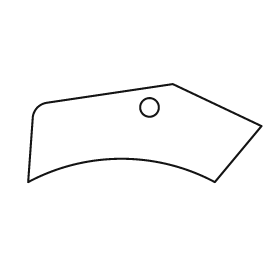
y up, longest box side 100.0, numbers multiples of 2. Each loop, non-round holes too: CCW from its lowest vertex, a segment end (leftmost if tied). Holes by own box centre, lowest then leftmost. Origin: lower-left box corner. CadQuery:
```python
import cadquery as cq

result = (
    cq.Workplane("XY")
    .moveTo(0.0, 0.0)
    .threePointArc((40.0, 10.0), (80.0, 0.0))
    .lineTo(100.0, 24.0)
    .lineTo(62.0, 42.0)
    .lineTo(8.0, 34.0)
    .threePointArc((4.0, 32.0), (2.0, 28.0))
    .close()
    .moveTo(52.0, 32.0)
    .circle(4.0)
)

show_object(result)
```